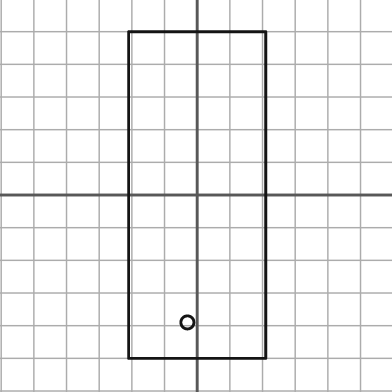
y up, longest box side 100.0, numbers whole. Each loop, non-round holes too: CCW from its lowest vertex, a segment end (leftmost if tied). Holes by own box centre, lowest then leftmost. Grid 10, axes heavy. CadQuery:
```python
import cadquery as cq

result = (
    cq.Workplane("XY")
    .moveTo(-21.0, -50.0)
    .lineTo(21.0, -50.0)
    .lineTo(21.0, 50.0)
    .lineTo(-21.0, 50.0)
    .close()
    .moveTo(-3.0, -39.0)
    .circle(2.0)
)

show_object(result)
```